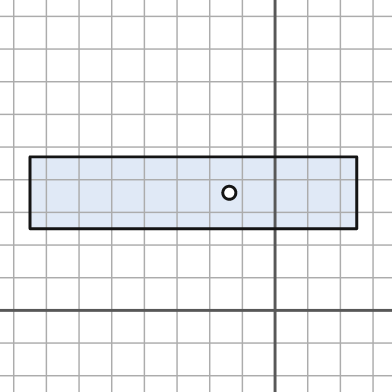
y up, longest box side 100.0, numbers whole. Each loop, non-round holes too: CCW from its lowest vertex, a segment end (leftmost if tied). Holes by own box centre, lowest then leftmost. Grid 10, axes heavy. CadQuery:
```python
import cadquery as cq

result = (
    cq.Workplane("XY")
    .moveTo(-75.0, 25.0)
    .lineTo(25.0, 25.0)
    .lineTo(25.0, 47.0)
    .lineTo(-75.0, 47.0)
    .close()
    .moveTo(-14.0, 36.0)
    .circle(2.0)
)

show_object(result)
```